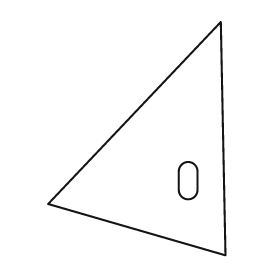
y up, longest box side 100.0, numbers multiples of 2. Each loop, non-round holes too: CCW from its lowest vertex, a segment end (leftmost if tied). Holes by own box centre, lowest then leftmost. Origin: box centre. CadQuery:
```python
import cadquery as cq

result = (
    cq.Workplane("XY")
    .moveTo(38.0, -50.0)
    .lineTo(36.0, 50.0)
    .lineTo(-38.0, -28.0)
    .close()
    .moveTo(18.0, -22.0)
    .threePointArc((22.0, -26.0), (26.0, -22.0))
    .lineTo(26.0, -14.0)
    .threePointArc((22.0, -10.0), (18.0, -14.0))
    .close()
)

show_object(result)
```